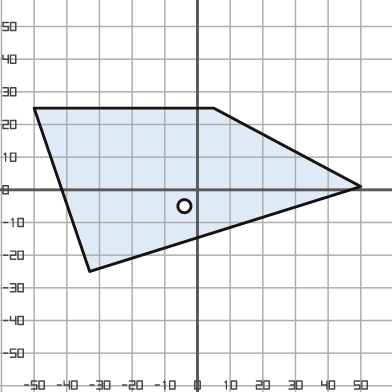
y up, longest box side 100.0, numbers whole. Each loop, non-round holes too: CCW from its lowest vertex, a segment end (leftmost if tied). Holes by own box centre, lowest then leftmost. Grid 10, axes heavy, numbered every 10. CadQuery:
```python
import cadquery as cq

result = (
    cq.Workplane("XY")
    .moveTo(-33.0, -25.0)
    .lineTo(50.0, 1.0)
    .lineTo(5.0, 25.0)
    .lineTo(-50.0, 25.0)
    .close()
    .moveTo(-4.0, -5.0)
    .circle(2.0)
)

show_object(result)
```